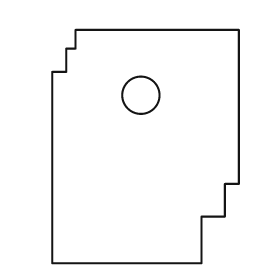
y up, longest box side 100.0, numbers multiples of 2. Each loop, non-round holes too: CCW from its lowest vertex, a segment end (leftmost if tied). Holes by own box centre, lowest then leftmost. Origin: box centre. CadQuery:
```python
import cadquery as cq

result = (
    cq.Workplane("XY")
    .moveTo(-40.0, -50.0)
    .lineTo(24.0, -50.0)
    .lineTo(24.0, -30.0)
    .lineTo(34.0, -30.0)
    .lineTo(34.0, -16.0)
    .lineTo(40.0, -16.0)
    .lineTo(40.0, 50.0)
    .lineTo(-30.0, 50.0)
    .lineTo(-30.0, 42.0)
    .lineTo(-34.0, 42.0)
    .lineTo(-34.0, 32.0)
    .lineTo(-40.0, 32.0)
    .close()
    .moveTo(-2.0, 22.0)
    .circle(8.0)
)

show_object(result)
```